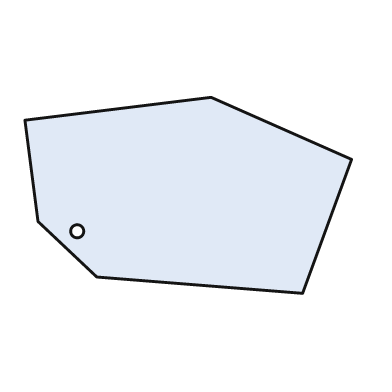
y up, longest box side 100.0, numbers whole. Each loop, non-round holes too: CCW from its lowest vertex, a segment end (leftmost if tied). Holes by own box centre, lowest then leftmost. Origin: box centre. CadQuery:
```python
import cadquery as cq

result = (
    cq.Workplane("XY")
    .moveTo(35.0, -30.0)
    .lineTo(50.0, 11.0)
    .lineTo(7.0, 30.0)
    .lineTo(-50.0, 23.0)
    .lineTo(-46.0, -8.0)
    .lineTo(-28.0, -25.0)
    .close()
    .moveTo(-34.0, -11.0)
    .circle(2.0)
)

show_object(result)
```